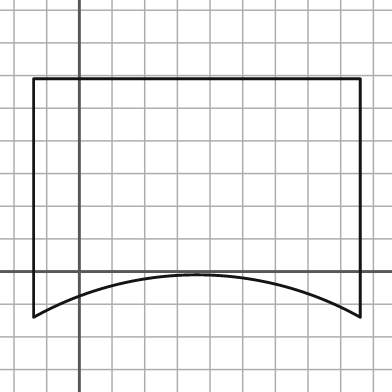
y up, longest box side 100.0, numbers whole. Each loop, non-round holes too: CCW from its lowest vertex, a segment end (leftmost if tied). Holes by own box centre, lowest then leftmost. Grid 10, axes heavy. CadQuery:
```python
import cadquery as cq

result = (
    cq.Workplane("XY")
    .moveTo(-14.0, -14.0)
    .threePointArc((36.0, -1.0), (86.0, -14.0))
    .lineTo(86.0, 59.0)
    .lineTo(-14.0, 59.0)
    .close()
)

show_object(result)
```